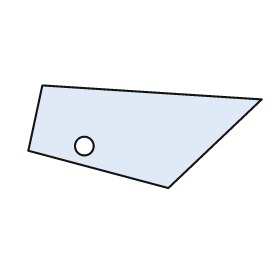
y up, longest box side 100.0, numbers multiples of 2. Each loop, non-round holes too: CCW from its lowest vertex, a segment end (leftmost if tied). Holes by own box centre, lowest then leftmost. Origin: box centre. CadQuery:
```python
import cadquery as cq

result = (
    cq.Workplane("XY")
    .moveTo(10.0, -22.0)
    .lineTo(50.0, 16.0)
    .lineTo(-44.0, 22.0)
    .lineTo(-50.0, -6.0)
    .close()
    .moveTo(-26.0, -4.0)
    .circle(4.0)
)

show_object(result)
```